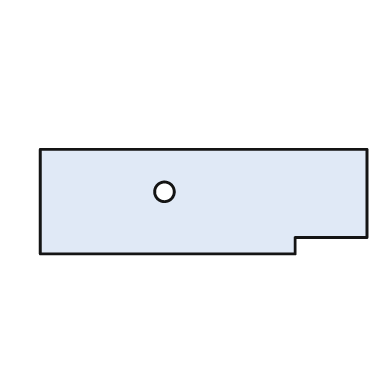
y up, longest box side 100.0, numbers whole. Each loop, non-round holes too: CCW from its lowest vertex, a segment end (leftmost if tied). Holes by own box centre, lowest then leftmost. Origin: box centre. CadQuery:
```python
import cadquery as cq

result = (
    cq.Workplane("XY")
    .moveTo(-50.0, -16.0)
    .lineTo(28.0, -16.0)
    .lineTo(28.0, -11.0)
    .lineTo(50.0, -11.0)
    .lineTo(50.0, 16.0)
    .lineTo(-50.0, 16.0)
    .close()
    .moveTo(-12.0, 3.0)
    .circle(3.0)
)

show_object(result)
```